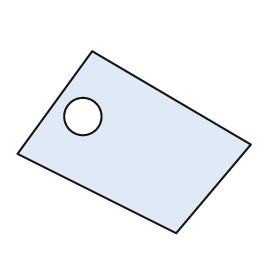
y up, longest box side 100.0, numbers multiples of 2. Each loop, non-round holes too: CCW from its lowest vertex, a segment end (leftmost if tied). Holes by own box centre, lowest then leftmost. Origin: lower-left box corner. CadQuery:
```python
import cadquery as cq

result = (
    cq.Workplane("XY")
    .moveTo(68.0, 0.0)
    .lineTo(100.0, 38.0)
    .lineTo(32.0, 78.0)
    .lineTo(0.0, 34.0)
    .close()
    .moveTo(28.0, 50.0)
    .circle(8.0)
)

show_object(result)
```